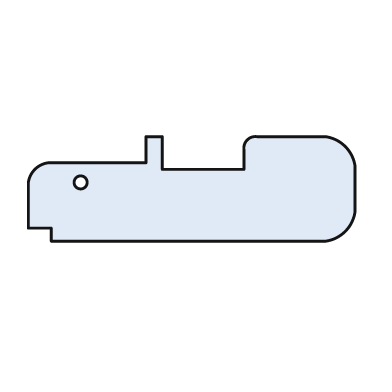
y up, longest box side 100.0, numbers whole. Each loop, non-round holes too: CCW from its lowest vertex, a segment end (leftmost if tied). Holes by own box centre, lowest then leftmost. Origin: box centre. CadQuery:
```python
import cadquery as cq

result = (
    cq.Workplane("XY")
    .moveTo(-43.0, -16.0)
    .lineTo(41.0, -16.0)
    .threePointArc((47.0, -13.0), (50.0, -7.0))
    .lineTo(50.0, 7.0)
    .threePointArc((47.0, 13.0), (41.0, 16.0))
    .lineTo(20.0, 16.0)
    .threePointArc((17.0, 15.0), (16.0, 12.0))
    .lineTo(16.0, 6.0)
    .lineTo(-9.0, 6.0)
    .lineTo(-9.0, 16.0)
    .lineTo(-14.0, 16.0)
    .lineTo(-14.0, 8.0)
    .lineTo(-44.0, 8.0)
    .threePointArc((-48.0, 6.0), (-50.0, 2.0))
    .lineTo(-50.0, -12.0)
    .lineTo(-43.0, -12.0)
    .close()
    .moveTo(-34.0, 2.0)
    .circle(2.0)
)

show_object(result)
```